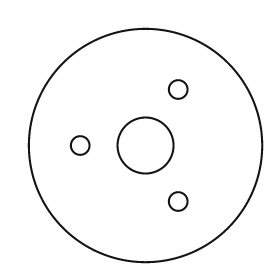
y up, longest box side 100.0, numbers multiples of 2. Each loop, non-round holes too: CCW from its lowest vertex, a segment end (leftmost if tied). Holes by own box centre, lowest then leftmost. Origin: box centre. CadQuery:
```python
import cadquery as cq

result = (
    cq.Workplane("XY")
    .moveTo(0.0, 0.0)
    .circle(50.0)
    .moveTo(14.0, -24.0)
    .circle(4.0)
    .moveTo(-28.0, 0.0)
    .circle(4.0)
    .moveTo(0.0, 0.0)
    .circle(12.0)
    .moveTo(14.0, 24.0)
    .circle(4.0)
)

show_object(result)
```